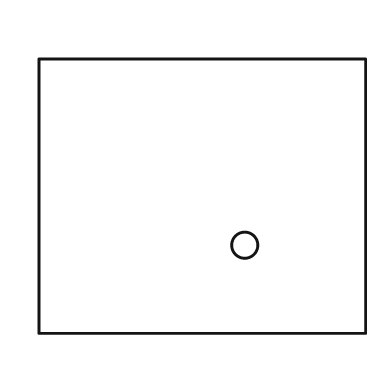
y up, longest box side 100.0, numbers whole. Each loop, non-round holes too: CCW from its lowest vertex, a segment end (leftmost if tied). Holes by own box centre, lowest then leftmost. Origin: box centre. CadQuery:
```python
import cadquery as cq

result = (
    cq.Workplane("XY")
    .moveTo(-50.0, -42.0)
    .lineTo(50.0, -42.0)
    .lineTo(50.0, 42.0)
    .lineTo(-50.0, 42.0)
    .close()
    .moveTo(13.0, -15.0)
    .circle(4.0)
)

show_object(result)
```